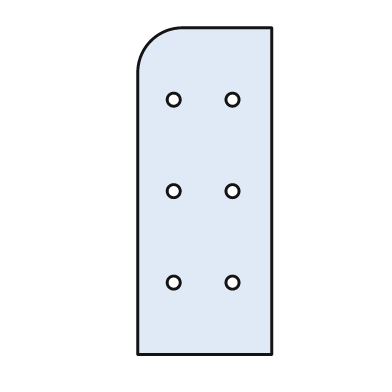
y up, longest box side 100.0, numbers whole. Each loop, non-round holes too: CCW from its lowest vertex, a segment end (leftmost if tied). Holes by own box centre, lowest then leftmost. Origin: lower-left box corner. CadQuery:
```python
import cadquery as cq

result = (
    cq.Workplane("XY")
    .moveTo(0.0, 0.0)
    .lineTo(41.0, 0.0)
    .lineTo(41.0, 100.0)
    .lineTo(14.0, 100.0)
    .threePointArc((4.0, 96.0), (0.0, 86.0))
    .close()
    .moveTo(11.0, 22.0)
    .circle(2.0)
    .moveTo(29.0, 22.0)
    .circle(2.0)
    .moveTo(11.0, 50.0)
    .circle(2.0)
    .moveTo(29.0, 50.0)
    .circle(2.0)
    .moveTo(11.0, 78.0)
    .circle(2.0)
    .moveTo(29.0, 78.0)
    .circle(2.0)
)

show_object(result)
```